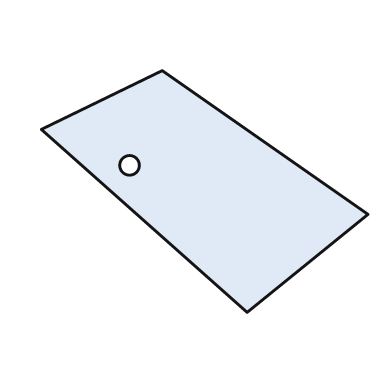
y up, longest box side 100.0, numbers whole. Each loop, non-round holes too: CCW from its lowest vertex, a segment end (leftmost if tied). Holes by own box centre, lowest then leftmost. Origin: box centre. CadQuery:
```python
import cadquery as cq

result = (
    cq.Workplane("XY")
    .moveTo(13.0, -37.0)
    .lineTo(50.0, -7.0)
    .lineTo(-13.0, 37.0)
    .lineTo(-50.0, 19.0)
    .close()
    .moveTo(-23.0, 8.0)
    .circle(3.0)
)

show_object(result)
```